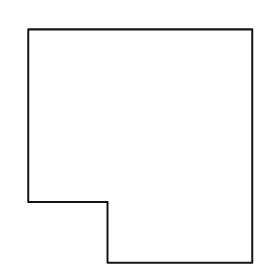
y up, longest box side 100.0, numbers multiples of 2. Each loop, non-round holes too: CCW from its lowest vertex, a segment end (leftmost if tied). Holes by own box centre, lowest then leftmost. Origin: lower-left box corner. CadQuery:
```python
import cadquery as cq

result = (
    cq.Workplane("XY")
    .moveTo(34.0, 0.0)
    .lineTo(96.0, 0.0)
    .lineTo(96.0, 100.0)
    .lineTo(0.0, 100.0)
    .lineTo(0.0, 26.0)
    .lineTo(34.0, 26.0)
    .close()
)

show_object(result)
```